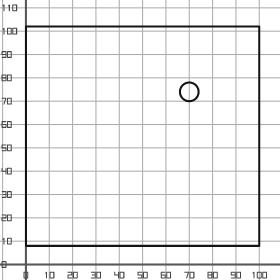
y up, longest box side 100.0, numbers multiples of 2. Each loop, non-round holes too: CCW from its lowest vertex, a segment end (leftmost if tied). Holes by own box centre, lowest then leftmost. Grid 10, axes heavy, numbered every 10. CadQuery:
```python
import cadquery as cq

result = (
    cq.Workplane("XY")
    .moveTo(0.0, 8.0)
    .lineTo(100.0, 8.0)
    .lineTo(100.0, 102.0)
    .lineTo(0.0, 102.0)
    .close()
    .moveTo(70.0, 74.0)
    .circle(4.0)
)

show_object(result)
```